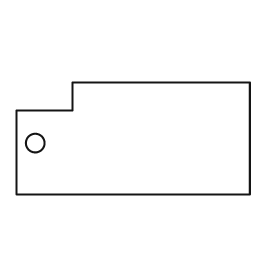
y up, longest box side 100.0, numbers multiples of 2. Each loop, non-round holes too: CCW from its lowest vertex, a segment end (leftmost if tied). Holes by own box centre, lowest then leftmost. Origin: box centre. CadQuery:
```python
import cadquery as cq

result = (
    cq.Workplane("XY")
    .moveTo(-50.0, -24.0)
    .lineTo(50.0, -24.0)
    .lineTo(50.0, 24.0)
    .lineTo(-26.0, 24.0)
    .lineTo(-26.0, 12.0)
    .lineTo(-50.0, 12.0)
    .close()
    .moveTo(-42.0, -2.0)
    .circle(4.0)
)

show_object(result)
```